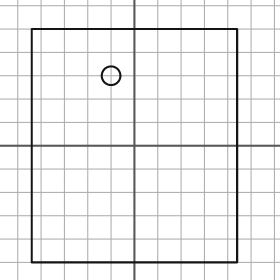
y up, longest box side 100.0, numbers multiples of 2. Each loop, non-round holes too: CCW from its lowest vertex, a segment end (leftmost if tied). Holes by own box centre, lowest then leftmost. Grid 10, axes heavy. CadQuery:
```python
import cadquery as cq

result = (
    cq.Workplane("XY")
    .moveTo(-44.0, -50.0)
    .lineTo(44.0, -50.0)
    .lineTo(44.0, 50.0)
    .lineTo(-44.0, 50.0)
    .close()
    .moveTo(-10.0, 30.0)
    .circle(4.0)
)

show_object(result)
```